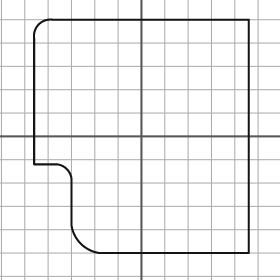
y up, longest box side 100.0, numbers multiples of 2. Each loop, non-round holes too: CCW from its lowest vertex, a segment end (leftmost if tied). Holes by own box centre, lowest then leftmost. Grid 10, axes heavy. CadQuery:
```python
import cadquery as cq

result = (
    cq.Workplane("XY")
    .moveTo(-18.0, -50.0)
    .lineTo(46.0, -50.0)
    .lineTo(46.0, 50.0)
    .lineTo(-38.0, 50.0)
    .threePointArc((-44.0, 48.0), (-46.0, 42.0))
    .lineTo(-46.0, -12.0)
    .lineTo(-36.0, -12.0)
    .threePointArc((-32.0, -14.0), (-30.0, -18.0))
    .lineTo(-30.0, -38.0)
    .threePointArc((-26.0, -46.0), (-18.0, -50.0))
    .close()
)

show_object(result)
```